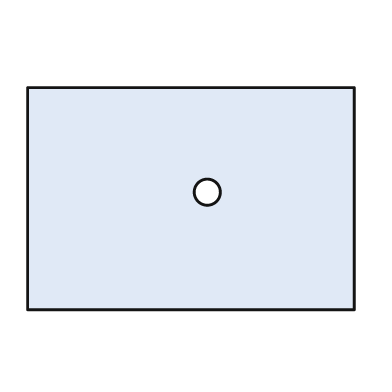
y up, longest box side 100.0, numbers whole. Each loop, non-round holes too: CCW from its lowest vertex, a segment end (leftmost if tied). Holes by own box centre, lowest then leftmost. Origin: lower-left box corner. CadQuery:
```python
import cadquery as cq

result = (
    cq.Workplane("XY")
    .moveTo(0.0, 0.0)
    .lineTo(100.0, 0.0)
    .lineTo(100.0, 68.0)
    .lineTo(0.0, 68.0)
    .close()
    .moveTo(55.0, 36.0)
    .circle(4.0)
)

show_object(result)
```